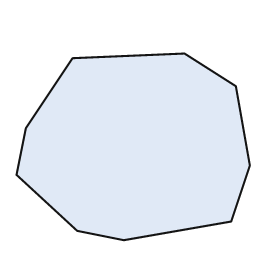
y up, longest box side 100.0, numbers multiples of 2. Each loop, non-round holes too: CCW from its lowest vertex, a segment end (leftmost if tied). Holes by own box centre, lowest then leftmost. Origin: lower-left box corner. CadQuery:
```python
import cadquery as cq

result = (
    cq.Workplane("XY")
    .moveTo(46.0, 0.0)
    .lineTo(92.0, 8.0)
    .lineTo(100.0, 32.0)
    .lineTo(94.0, 66.0)
    .lineTo(72.0, 80.0)
    .lineTo(24.0, 78.0)
    .lineTo(4.0, 48.0)
    .lineTo(0.0, 28.0)
    .lineTo(26.0, 4.0)
    .close()
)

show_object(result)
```